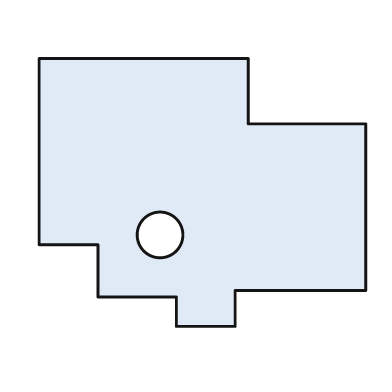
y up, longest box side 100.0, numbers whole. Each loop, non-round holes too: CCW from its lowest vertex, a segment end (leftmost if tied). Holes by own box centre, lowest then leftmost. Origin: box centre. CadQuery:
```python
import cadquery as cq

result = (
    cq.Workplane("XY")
    .moveTo(-8.0, -41.0)
    .lineTo(10.0, -41.0)
    .lineTo(10.0, -30.0)
    .lineTo(50.0, -30.0)
    .lineTo(50.0, 21.0)
    .lineTo(14.0, 21.0)
    .lineTo(14.0, 41.0)
    .lineTo(-50.0, 41.0)
    .lineTo(-50.0, -16.0)
    .lineTo(-32.0, -16.0)
    .lineTo(-32.0, -32.0)
    .lineTo(-8.0, -32.0)
    .close()
    .moveTo(-13.0, -13.0)
    .circle(7.0)
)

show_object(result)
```